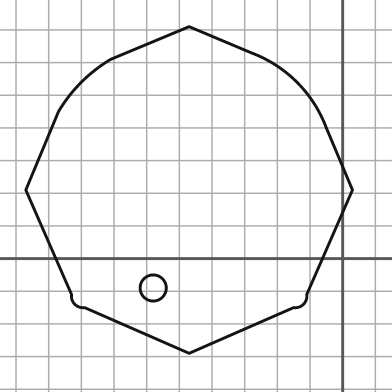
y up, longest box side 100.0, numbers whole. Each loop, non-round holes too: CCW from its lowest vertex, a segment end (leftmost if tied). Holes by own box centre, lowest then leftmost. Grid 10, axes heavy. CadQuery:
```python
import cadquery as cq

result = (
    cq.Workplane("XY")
    .moveTo(-47.0, -29.0)
    .lineTo(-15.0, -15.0)
    .threePointArc((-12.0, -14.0), (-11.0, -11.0))
    .lineTo(3.0, 21.0)
    .lineTo(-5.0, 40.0)
    .threePointArc((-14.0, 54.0), (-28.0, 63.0))
    .lineTo(-47.0, 71.0)
    .lineTo(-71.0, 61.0)
    .threePointArc((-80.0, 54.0), (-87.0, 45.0))
    .lineTo(-97.0, 21.0)
    .lineTo(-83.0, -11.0)
    .threePointArc((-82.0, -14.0), (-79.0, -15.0))
    .close()
    .moveTo(-58.0, -9.0)
    .circle(4.0)
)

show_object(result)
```